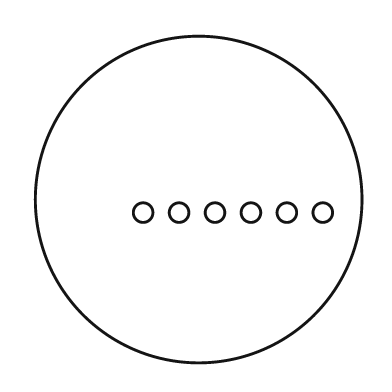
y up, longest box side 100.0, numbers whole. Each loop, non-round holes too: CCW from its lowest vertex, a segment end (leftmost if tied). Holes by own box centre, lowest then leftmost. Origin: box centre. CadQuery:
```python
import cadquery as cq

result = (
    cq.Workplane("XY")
    .moveTo(0.0, 0.0)
    .circle(50.0)
    .moveTo(-17.0, -4.0)
    .circle(3.0)
    .moveTo(-6.0, -4.0)
    .circle(3.0)
    .moveTo(5.0, -4.0)
    .circle(3.0)
    .moveTo(16.0, -4.0)
    .circle(3.0)
    .moveTo(27.0, -4.0)
    .circle(3.0)
    .moveTo(38.0, -4.0)
    .circle(3.0)
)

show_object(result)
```